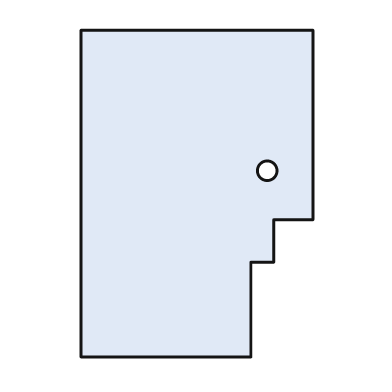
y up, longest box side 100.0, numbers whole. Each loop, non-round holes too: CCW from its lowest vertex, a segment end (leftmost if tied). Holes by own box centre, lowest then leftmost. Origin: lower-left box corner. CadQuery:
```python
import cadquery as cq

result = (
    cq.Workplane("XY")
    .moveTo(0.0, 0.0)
    .lineTo(52.0, 0.0)
    .lineTo(52.0, 29.0)
    .lineTo(59.0, 29.0)
    .lineTo(59.0, 42.0)
    .lineTo(71.0, 42.0)
    .lineTo(71.0, 100.0)
    .lineTo(0.0, 100.0)
    .close()
    .moveTo(57.0, 57.0)
    .circle(3.0)
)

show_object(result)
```